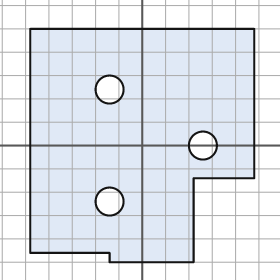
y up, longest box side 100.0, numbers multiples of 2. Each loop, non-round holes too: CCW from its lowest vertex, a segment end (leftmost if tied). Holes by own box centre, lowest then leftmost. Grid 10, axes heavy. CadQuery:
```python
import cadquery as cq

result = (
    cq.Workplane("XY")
    .moveTo(-14.0, -50.0)
    .lineTo(22.0, -50.0)
    .lineTo(22.0, -14.0)
    .lineTo(48.0, -14.0)
    .lineTo(48.0, 50.0)
    .lineTo(-48.0, 50.0)
    .lineTo(-48.0, -46.0)
    .lineTo(-14.0, -46.0)
    .close()
    .moveTo(-14.0, -24.0)
    .circle(6.0)
    .moveTo(26.0, 0.0)
    .circle(6.0)
    .moveTo(-14.0, 24.0)
    .circle(6.0)
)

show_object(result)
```